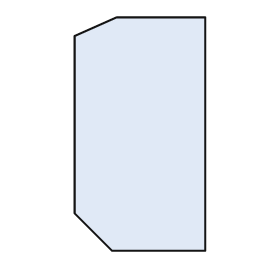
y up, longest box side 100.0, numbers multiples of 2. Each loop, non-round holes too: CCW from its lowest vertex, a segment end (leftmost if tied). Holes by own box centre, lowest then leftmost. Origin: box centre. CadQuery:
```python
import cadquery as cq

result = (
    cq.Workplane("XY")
    .moveTo(-12.0, -50.0)
    .lineTo(28.0, -50.0)
    .lineTo(28.0, 50.0)
    .lineTo(-10.0, 50.0)
    .lineTo(-28.0, 42.0)
    .lineTo(-28.0, -34.0)
    .close()
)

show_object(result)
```